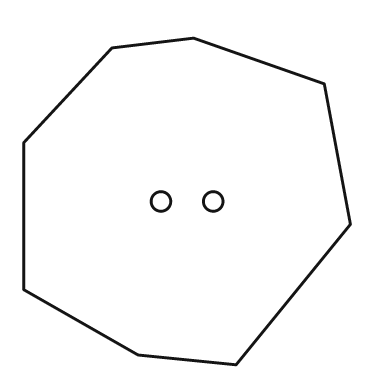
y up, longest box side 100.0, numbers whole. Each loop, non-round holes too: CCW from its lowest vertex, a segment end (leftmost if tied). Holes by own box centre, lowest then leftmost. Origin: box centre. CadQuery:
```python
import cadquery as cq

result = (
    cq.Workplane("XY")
    .moveTo(15.0, -50.0)
    .lineTo(50.0, -7.0)
    .lineTo(42.0, 36.0)
    .lineTo(2.0, 50.0)
    .lineTo(-23.0, 47.0)
    .lineTo(-50.0, 18.0)
    .lineTo(-50.0, -27.0)
    .lineTo(-15.0, -47.0)
    .close()
    .moveTo(-8.0, 0.0)
    .circle(3.0)
    .moveTo(8.0, 0.0)
    .circle(3.0)
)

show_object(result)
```